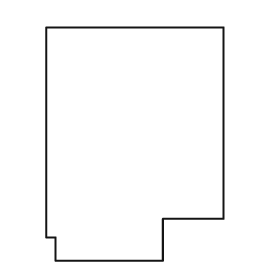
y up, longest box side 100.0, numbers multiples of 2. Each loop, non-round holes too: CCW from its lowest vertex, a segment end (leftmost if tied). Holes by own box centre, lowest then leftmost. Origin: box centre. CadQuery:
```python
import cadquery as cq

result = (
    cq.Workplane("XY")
    .moveTo(-34.0, -50.0)
    .lineTo(12.0, -50.0)
    .lineTo(12.0, -32.0)
    .lineTo(38.0, -32.0)
    .lineTo(38.0, 50.0)
    .lineTo(-38.0, 50.0)
    .lineTo(-38.0, -40.0)
    .lineTo(-34.0, -40.0)
    .close()
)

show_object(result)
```